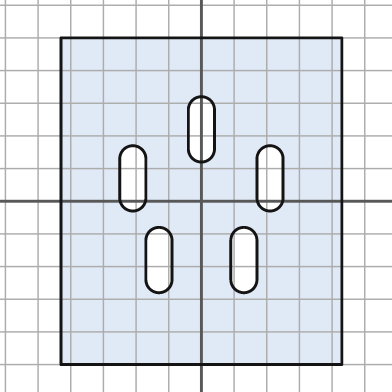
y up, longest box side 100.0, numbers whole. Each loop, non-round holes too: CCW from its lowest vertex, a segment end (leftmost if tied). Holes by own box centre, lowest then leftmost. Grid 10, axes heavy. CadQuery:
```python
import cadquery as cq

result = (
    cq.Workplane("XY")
    .moveTo(-43.0, -50.0)
    .lineTo(43.0, -50.0)
    .lineTo(43.0, 50.0)
    .lineTo(-43.0, 50.0)
    .close()
    .moveTo(-17.0, -24.0)
    .threePointArc((-13.0, -28.0), (-9.0, -24.0))
    .lineTo(-9.0, -12.0)
    .threePointArc((-13.0, -8.0), (-17.0, -12.0))
    .close()
    .moveTo(9.0, -24.0)
    .threePointArc((13.0, -28.0), (17.0, -24.0))
    .lineTo(17.0, -12.0)
    .threePointArc((13.0, -8.0), (9.0, -12.0))
    .close()
    .moveTo(-25.0, 1.0)
    .threePointArc((-21.0, -3.0), (-17.0, 1.0))
    .lineTo(-17.0, 13.0)
    .threePointArc((-21.0, 17.0), (-25.0, 13.0))
    .close()
    .moveTo(17.0, 1.0)
    .threePointArc((21.0, -3.0), (25.0, 1.0))
    .lineTo(25.0, 13.0)
    .threePointArc((21.0, 17.0), (17.0, 13.0))
    .close()
    .moveTo(-4.0, 16.0)
    .threePointArc((0.0, 12.0), (4.0, 16.0))
    .lineTo(4.0, 28.0)
    .threePointArc((0.0, 32.0), (-4.0, 28.0))
    .close()
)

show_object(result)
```